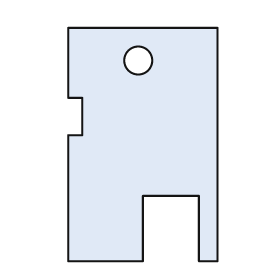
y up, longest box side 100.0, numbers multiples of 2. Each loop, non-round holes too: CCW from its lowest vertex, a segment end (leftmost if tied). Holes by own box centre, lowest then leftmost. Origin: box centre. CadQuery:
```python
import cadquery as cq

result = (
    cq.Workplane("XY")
    .moveTo(-32.0, -50.0)
    .lineTo(0.0, -50.0)
    .lineTo(0.0, -22.0)
    .lineTo(24.0, -22.0)
    .lineTo(24.0, -50.0)
    .lineTo(32.0, -50.0)
    .lineTo(32.0, 50.0)
    .lineTo(-32.0, 50.0)
    .lineTo(-32.0, 20.0)
    .lineTo(-26.0, 20.0)
    .lineTo(-26.0, 4.0)
    .lineTo(-32.0, 4.0)
    .close()
    .moveTo(-2.0, 36.0)
    .circle(6.0)
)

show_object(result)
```